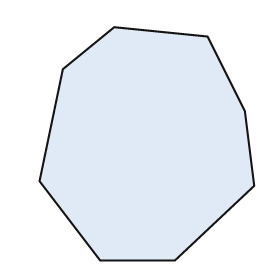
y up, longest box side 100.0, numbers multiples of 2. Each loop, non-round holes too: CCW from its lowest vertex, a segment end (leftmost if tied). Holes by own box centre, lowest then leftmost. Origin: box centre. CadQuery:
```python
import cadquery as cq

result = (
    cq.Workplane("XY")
    .moveTo(-20.0, -50.0)
    .lineTo(12.0, -50.0)
    .lineTo(46.0, -18.0)
    .lineTo(42.0, 14.0)
    .lineTo(26.0, 46.0)
    .lineTo(-14.0, 50.0)
    .lineTo(-36.0, 32.0)
    .lineTo(-46.0, -16.0)
    .close()
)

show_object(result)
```